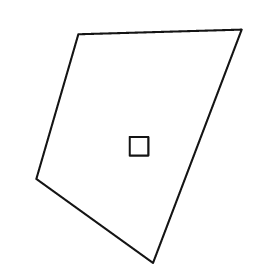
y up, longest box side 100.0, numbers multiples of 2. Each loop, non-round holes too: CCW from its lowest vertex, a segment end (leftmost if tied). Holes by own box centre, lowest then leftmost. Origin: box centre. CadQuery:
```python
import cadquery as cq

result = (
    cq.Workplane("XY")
    .moveTo(6.0, -50.0)
    .lineTo(44.0, 50.0)
    .lineTo(-26.0, 48.0)
    .lineTo(-44.0, -14.0)
    .close()
    .moveTo(-4.0, -4.0)
    .lineTo(4.0, -4.0)
    .lineTo(4.0, 4.0)
    .lineTo(-4.0, 4.0)
    .close()
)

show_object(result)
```